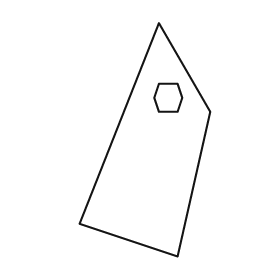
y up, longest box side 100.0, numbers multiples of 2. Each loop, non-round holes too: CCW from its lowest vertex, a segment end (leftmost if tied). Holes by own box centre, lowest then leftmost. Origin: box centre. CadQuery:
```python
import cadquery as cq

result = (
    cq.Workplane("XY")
    .moveTo(14.0, -50.0)
    .lineTo(28.0, 12.0)
    .lineTo(6.0, 50.0)
    .lineTo(-28.0, -36.0)
    .close()
    .moveTo(6.0, 12.0)
    .lineTo(14.0, 12.0)
    .lineTo(16.0, 18.0)
    .lineTo(14.0, 24.0)
    .lineTo(6.0, 24.0)
    .lineTo(4.0, 18.0)
    .close()
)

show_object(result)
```